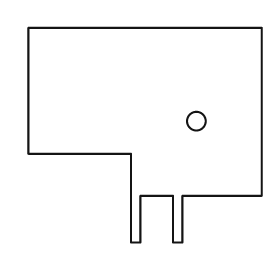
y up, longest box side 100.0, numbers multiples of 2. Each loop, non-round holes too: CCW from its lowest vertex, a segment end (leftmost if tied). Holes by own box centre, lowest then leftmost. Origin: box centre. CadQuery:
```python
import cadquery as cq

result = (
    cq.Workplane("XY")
    .moveTo(-6.0, -46.0)
    .lineTo(-2.0, -46.0)
    .lineTo(-2.0, -26.0)
    .lineTo(12.0, -26.0)
    .lineTo(12.0, -46.0)
    .lineTo(16.0, -46.0)
    .lineTo(16.0, -26.0)
    .lineTo(50.0, -26.0)
    .lineTo(50.0, 46.0)
    .lineTo(-50.0, 46.0)
    .lineTo(-50.0, -8.0)
    .lineTo(-6.0, -8.0)
    .close()
    .moveTo(22.0, 6.0)
    .circle(4.0)
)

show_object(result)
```